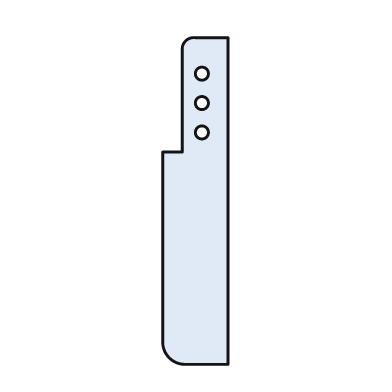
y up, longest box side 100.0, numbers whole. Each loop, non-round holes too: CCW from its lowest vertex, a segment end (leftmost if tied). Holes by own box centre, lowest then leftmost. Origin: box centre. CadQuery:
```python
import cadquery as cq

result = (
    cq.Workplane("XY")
    .moveTo(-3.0, -50.0)
    .lineTo(10.0, -50.0)
    .lineTo(10.0, 50.0)
    .lineTo(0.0, 50.0)
    .threePointArc((-3.0, 49.0), (-4.0, 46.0))
    .lineTo(-4.0, 15.0)
    .lineTo(-10.0, 15.0)
    .lineTo(-10.0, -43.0)
    .threePointArc((-8.0, -48.0), (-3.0, -50.0))
    .close()
    .moveTo(2.0, 21.0)
    .circle(2.0)
    .moveTo(2.0, 30.0)
    .circle(2.0)
    .moveTo(2.0, 39.0)
    .circle(2.0)
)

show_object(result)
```